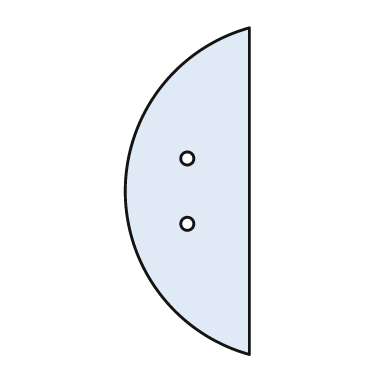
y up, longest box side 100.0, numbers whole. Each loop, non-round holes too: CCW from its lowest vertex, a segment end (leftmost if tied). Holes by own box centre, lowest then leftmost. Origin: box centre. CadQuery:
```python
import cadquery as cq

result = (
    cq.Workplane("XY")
    .moveTo(19.0, -50.0)
    .lineTo(19.0, 50.0)
    .threePointArc((-19.0, 0.0), (19.0, -50.0))
    .close()
    .moveTo(0.0, -10.0)
    .circle(2.0)
    .moveTo(0.0, 10.0)
    .circle(2.0)
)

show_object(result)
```